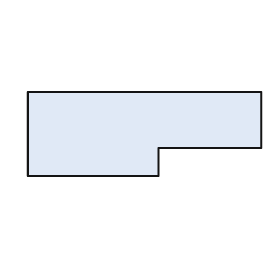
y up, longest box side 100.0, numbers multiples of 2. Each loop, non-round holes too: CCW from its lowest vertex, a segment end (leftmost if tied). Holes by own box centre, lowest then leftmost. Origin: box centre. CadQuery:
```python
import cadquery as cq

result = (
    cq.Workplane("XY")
    .moveTo(-50.0, -18.0)
    .lineTo(6.0, -18.0)
    .lineTo(6.0, -6.0)
    .lineTo(50.0, -6.0)
    .lineTo(50.0, 18.0)
    .lineTo(-50.0, 18.0)
    .close()
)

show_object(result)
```